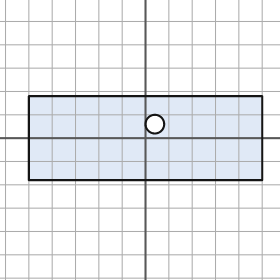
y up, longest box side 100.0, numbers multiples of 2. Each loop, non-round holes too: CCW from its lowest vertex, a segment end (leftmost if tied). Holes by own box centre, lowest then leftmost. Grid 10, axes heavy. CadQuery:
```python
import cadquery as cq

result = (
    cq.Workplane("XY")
    .moveTo(-50.0, -18.0)
    .lineTo(50.0, -18.0)
    .lineTo(50.0, 18.0)
    .lineTo(-50.0, 18.0)
    .close()
    .moveTo(4.0, 6.0)
    .circle(4.0)
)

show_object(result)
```